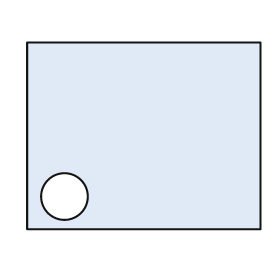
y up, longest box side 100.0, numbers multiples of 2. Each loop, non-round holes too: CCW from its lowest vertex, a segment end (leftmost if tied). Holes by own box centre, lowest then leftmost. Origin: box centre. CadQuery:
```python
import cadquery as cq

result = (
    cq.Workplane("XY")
    .moveTo(-50.0, -40.0)
    .lineTo(50.0, -40.0)
    .lineTo(50.0, 40.0)
    .lineTo(-50.0, 40.0)
    .close()
    .moveTo(-34.0, -26.0)
    .circle(10.0)
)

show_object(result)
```